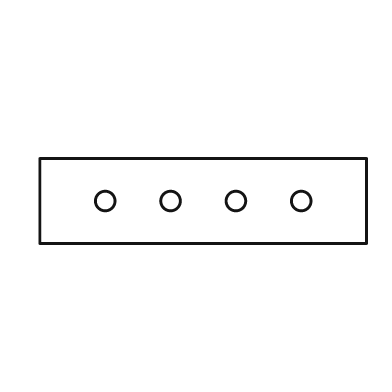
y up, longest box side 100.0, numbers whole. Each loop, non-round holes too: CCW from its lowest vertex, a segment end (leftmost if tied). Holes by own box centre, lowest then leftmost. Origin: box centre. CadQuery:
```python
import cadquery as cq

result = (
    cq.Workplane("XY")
    .moveTo(-50.0, -13.0)
    .lineTo(50.0, -13.0)
    .lineTo(50.0, 13.0)
    .lineTo(-50.0, 13.0)
    .close()
    .moveTo(-30.0, 0.0)
    .circle(3.0)
    .moveTo(-10.0, 0.0)
    .circle(3.0)
    .moveTo(10.0, 0.0)
    .circle(3.0)
    .moveTo(30.0, 0.0)
    .circle(3.0)
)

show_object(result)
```